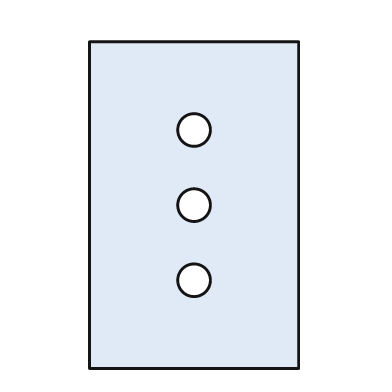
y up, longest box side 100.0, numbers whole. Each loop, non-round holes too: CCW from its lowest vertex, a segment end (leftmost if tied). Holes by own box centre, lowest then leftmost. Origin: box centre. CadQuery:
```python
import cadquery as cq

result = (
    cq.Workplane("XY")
    .moveTo(-32.0, -50.0)
    .lineTo(32.0, -50.0)
    .lineTo(32.0, 50.0)
    .lineTo(-32.0, 50.0)
    .close()
    .moveTo(0.0, -23.0)
    .circle(5.0)
    .moveTo(0.0, 0.0)
    .circle(5.0)
    .moveTo(0.0, 23.0)
    .circle(5.0)
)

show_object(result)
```